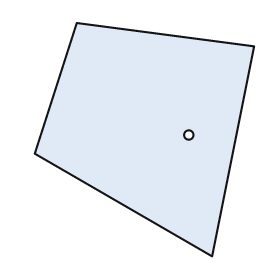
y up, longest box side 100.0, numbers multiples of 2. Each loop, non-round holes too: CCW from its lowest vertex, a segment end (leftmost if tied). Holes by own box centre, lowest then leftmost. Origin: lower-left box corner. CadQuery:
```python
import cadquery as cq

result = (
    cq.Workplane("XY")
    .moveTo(76.0, 0.0)
    .lineTo(94.0, 90.0)
    .lineTo(18.0, 100.0)
    .lineTo(0.0, 44.0)
    .close()
    .moveTo(66.0, 52.0)
    .circle(2.0)
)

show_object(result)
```